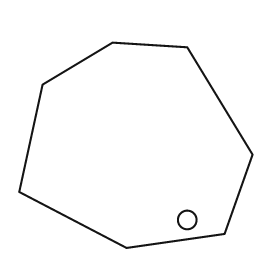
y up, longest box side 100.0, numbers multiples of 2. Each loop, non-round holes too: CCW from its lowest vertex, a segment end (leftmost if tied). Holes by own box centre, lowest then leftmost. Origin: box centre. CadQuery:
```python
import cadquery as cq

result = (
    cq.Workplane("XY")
    .moveTo(-4.0, -44.0)
    .lineTo(38.0, -38.0)
    .lineTo(50.0, -4.0)
    .lineTo(22.0, 42.0)
    .lineTo(-10.0, 44.0)
    .lineTo(-40.0, 26.0)
    .lineTo(-50.0, -20.0)
    .close()
    .moveTo(22.0, -32.0)
    .circle(4.0)
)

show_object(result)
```